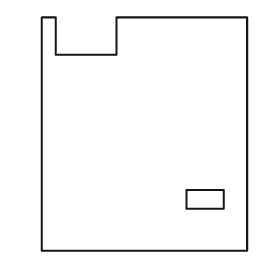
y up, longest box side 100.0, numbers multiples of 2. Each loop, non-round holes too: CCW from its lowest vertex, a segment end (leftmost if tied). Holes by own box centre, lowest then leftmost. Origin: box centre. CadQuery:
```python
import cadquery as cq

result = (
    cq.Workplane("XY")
    .moveTo(-44.0, -50.0)
    .lineTo(44.0, -50.0)
    .lineTo(44.0, 50.0)
    .lineTo(-12.0, 50.0)
    .lineTo(-12.0, 34.0)
    .lineTo(-38.0, 34.0)
    .lineTo(-38.0, 50.0)
    .lineTo(-44.0, 50.0)
    .close()
    .moveTo(18.0, -32.0)
    .lineTo(34.0, -32.0)
    .lineTo(34.0, -24.0)
    .lineTo(18.0, -24.0)
    .close()
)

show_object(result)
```